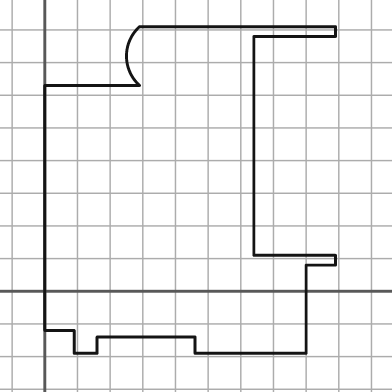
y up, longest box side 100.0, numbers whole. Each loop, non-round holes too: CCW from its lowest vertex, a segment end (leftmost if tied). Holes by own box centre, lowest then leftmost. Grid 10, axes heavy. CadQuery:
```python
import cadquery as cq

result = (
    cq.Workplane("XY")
    .moveTo(9.0, -19.0)
    .lineTo(16.0, -19.0)
    .lineTo(16.0, -14.0)
    .lineTo(46.0, -14.0)
    .lineTo(46.0, -19.0)
    .lineTo(80.0, -19.0)
    .lineTo(80.0, 8.0)
    .lineTo(89.0, 8.0)
    .lineTo(89.0, 11.0)
    .lineTo(64.0, 11.0)
    .lineTo(64.0, 78.0)
    .lineTo(89.0, 78.0)
    .lineTo(89.0, 81.0)
    .lineTo(29.0, 81.0)
    .threePointArc((25.0, 72.0), (29.0, 63.0))
    .lineTo(0.0, 63.0)
    .lineTo(0.0, -12.0)
    .lineTo(9.0, -12.0)
    .close()
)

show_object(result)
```